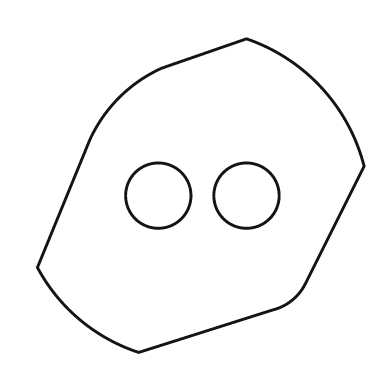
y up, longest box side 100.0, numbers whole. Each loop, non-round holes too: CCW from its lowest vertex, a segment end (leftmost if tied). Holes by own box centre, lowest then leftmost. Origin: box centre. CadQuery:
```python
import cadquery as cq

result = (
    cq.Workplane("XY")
    .moveTo(-19.0, -48.0)
    .lineTo(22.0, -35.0)
    .threePointArc((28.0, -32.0), (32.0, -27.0))
    .lineTo(50.0, 9.0)
    .threePointArc((37.0, 33.0), (14.0, 48.0))
    .lineTo(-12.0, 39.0)
    .threePointArc((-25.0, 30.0), (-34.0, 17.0))
    .lineTo(-50.0, -22.0)
    .threePointArc((-37.0, -38.0), (-19.0, -48.0))
    .close()
    .moveTo(-13.0, 0.0)
    .circle(10.0)
    .moveTo(14.0, 0.0)
    .circle(10.0)
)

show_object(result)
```